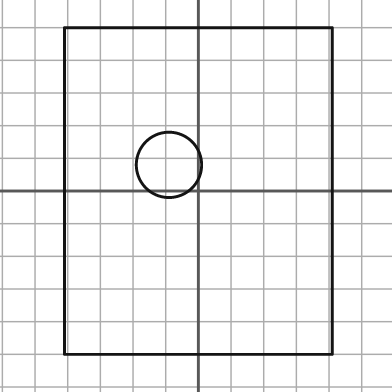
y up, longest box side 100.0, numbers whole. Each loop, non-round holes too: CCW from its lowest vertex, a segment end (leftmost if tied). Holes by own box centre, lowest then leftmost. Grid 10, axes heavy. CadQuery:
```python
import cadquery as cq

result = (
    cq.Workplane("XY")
    .moveTo(-41.0, -50.0)
    .lineTo(41.0, -50.0)
    .lineTo(41.0, 50.0)
    .lineTo(-41.0, 50.0)
    .close()
    .moveTo(-9.0, 8.0)
    .circle(10.0)
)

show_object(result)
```